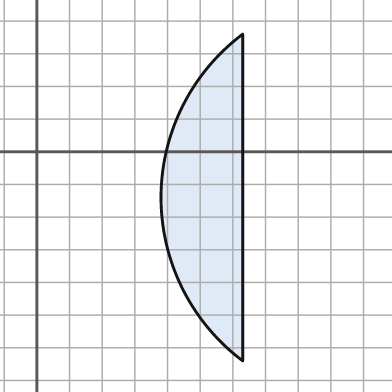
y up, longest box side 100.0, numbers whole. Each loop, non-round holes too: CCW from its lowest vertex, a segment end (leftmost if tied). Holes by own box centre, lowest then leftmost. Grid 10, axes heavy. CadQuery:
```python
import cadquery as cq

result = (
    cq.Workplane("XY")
    .moveTo(63.0, -64.0)
    .lineTo(63.0, 36.0)
    .threePointArc((38.0, -14.0), (63.0, -64.0))
    .close()
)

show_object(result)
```